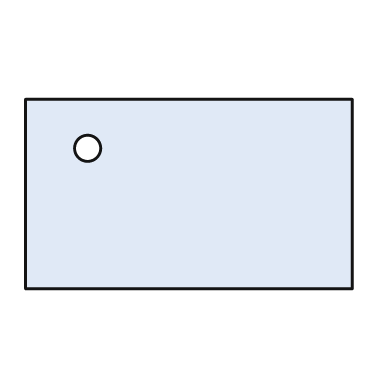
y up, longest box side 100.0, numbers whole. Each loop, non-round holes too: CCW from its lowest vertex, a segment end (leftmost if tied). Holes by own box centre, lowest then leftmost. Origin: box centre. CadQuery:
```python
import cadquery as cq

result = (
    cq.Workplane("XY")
    .moveTo(-50.0, -29.0)
    .lineTo(50.0, -29.0)
    .lineTo(50.0, 29.0)
    .lineTo(-50.0, 29.0)
    .close()
    .moveTo(-31.0, 14.0)
    .circle(4.0)
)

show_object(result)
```